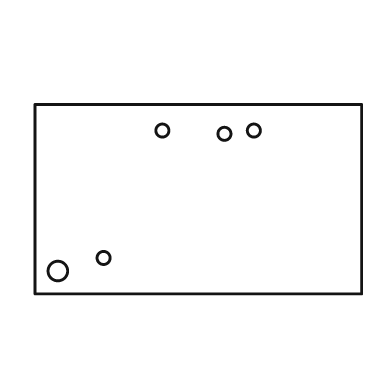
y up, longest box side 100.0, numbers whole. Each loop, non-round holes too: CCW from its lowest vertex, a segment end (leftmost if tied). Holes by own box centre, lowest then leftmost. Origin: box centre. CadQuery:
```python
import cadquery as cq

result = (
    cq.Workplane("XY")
    .moveTo(-50.0, -29.0)
    .lineTo(50.0, -29.0)
    .lineTo(50.0, 29.0)
    .lineTo(-50.0, 29.0)
    .close()
    .moveTo(-43.0, -22.0)
    .circle(3.0)
    .moveTo(-29.0, -18.0)
    .circle(2.0)
    .moveTo(8.0, 20.0)
    .circle(2.0)
    .moveTo(-11.0, 21.0)
    .circle(2.0)
    .moveTo(17.0, 21.0)
    .circle(2.0)
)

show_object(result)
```